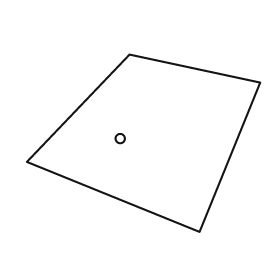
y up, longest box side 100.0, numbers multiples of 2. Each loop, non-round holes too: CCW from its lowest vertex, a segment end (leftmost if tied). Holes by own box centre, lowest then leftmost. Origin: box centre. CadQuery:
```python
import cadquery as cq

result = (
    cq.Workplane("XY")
    .moveTo(24.0, -38.0)
    .lineTo(50.0, 26.0)
    .lineTo(-6.0, 38.0)
    .lineTo(-50.0, -8.0)
    .close()
    .moveTo(-10.0, 2.0)
    .circle(2.0)
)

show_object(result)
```